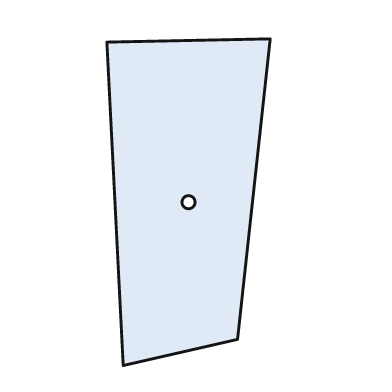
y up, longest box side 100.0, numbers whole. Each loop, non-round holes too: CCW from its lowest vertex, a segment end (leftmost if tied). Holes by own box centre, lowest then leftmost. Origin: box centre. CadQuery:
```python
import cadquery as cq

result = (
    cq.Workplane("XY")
    .moveTo(-20.0, -50.0)
    .lineTo(15.0, -42.0)
    .lineTo(25.0, 50.0)
    .lineTo(-25.0, 49.0)
    .close()
    .moveTo(0.0, 0.0)
    .circle(2.0)
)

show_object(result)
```